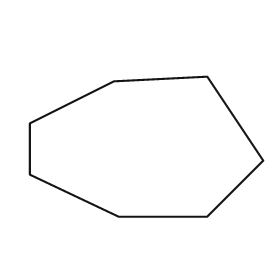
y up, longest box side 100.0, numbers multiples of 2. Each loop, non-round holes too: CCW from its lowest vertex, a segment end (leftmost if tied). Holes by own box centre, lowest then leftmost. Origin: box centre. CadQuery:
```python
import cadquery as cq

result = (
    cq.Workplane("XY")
    .moveTo(-12.0, -30.0)
    .lineTo(26.0, -30.0)
    .lineTo(50.0, -6.0)
    .lineTo(26.0, 30.0)
    .lineTo(-14.0, 28.0)
    .lineTo(-50.0, 10.0)
    .lineTo(-50.0, -12.0)
    .close()
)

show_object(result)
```